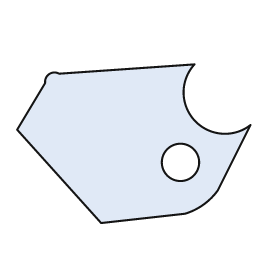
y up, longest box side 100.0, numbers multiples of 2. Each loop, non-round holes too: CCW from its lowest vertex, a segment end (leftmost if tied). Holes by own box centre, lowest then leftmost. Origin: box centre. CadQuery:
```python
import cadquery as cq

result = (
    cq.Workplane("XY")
    .moveTo(-14.0, -34.0)
    .lineTo(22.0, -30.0)
    .threePointArc((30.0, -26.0), (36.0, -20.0))
    .lineTo(50.0, 8.0)
    .threePointArc((26.0, 10.0), (26.0, 34.0))
    .lineTo(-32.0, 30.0)
    .threePointArc((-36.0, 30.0), (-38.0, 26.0))
    .lineTo(-50.0, 6.0)
    .close()
    .moveTo(20.0, -8.0)
    .circle(8.0)
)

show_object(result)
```